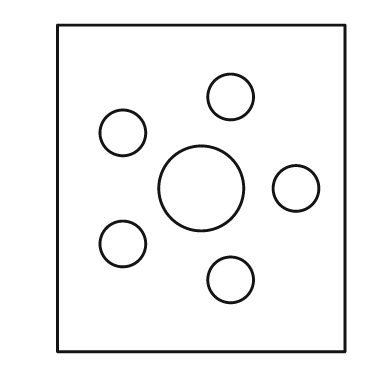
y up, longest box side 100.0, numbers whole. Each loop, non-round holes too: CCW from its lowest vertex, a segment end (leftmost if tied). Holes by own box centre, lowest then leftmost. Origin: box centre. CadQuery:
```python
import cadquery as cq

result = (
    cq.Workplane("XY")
    .moveTo(-44.0, -50.0)
    .lineTo(44.0, -50.0)
    .lineTo(44.0, 50.0)
    .lineTo(-44.0, 50.0)
    .close()
    .moveTo(9.0, -28.0)
    .circle(7.0)
    .moveTo(-24.0, -17.0)
    .circle(7.0)
    .moveTo(0.0, 0.0)
    .circle(13.0)
    .moveTo(29.0, 0.0)
    .circle(7.0)
    .moveTo(-24.0, 17.0)
    .circle(7.0)
    .moveTo(9.0, 28.0)
    .circle(7.0)
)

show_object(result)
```